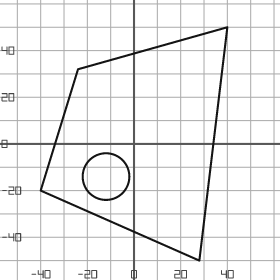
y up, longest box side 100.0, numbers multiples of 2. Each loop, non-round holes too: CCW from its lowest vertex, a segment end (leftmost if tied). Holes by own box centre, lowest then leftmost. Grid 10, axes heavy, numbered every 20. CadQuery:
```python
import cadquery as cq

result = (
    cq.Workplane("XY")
    .moveTo(28.0, -50.0)
    .lineTo(40.0, 50.0)
    .lineTo(-24.0, 32.0)
    .lineTo(-40.0, -20.0)
    .close()
    .moveTo(-12.0, -14.0)
    .circle(10.0)
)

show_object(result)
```